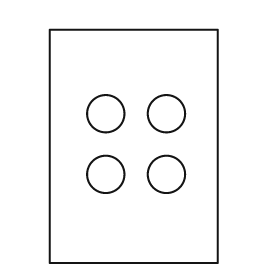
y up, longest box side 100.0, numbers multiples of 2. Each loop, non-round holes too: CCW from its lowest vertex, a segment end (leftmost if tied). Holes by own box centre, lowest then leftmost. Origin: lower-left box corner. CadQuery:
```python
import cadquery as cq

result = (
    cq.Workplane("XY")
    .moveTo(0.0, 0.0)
    .lineTo(72.0, 0.0)
    .lineTo(72.0, 100.0)
    .lineTo(0.0, 100.0)
    .close()
    .moveTo(24.0, 38.0)
    .circle(8.0)
    .moveTo(50.0, 38.0)
    .circle(8.0)
    .moveTo(24.0, 64.0)
    .circle(8.0)
    .moveTo(50.0, 64.0)
    .circle(8.0)
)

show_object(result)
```